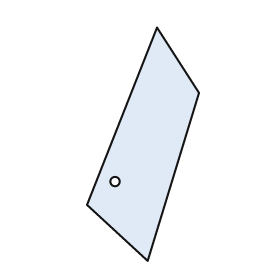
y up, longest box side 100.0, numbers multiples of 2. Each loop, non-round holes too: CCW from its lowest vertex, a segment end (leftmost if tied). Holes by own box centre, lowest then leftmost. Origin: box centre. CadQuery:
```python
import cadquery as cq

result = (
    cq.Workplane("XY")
    .moveTo(2.0, -50.0)
    .lineTo(24.0, 22.0)
    .lineTo(6.0, 50.0)
    .lineTo(-24.0, -26.0)
    .close()
    .moveTo(-12.0, -16.0)
    .circle(2.0)
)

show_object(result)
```